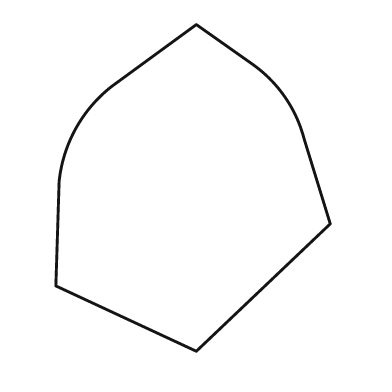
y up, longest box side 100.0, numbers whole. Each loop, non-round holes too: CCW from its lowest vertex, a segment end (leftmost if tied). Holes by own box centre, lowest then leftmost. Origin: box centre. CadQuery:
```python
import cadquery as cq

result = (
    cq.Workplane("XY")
    .moveTo(1.0, -50.0)
    .lineTo(42.0, -11.0)
    .lineTo(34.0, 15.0)
    .threePointArc((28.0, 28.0), (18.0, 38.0))
    .lineTo(1.0, 50.0)
    .lineTo(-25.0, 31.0)
    .threePointArc((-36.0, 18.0), (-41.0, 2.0))
    .lineTo(-42.0, -30.0)
    .close()
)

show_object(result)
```